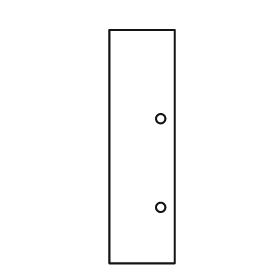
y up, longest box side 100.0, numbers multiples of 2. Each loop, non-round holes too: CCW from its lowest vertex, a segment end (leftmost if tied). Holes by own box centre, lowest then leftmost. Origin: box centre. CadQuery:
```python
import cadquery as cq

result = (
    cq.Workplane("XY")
    .moveTo(-14.0, -50.0)
    .lineTo(14.0, -50.0)
    .lineTo(14.0, 50.0)
    .lineTo(-14.0, 50.0)
    .close()
    .moveTo(8.0, -26.0)
    .circle(2.0)
    .moveTo(8.0, 12.0)
    .circle(2.0)
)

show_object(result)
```